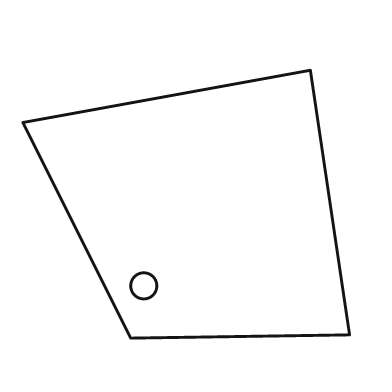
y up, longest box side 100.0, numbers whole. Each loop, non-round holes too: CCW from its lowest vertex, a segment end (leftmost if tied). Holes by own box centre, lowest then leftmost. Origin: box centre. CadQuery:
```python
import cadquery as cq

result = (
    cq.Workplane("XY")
    .moveTo(-17.0, -41.0)
    .lineTo(50.0, -40.0)
    .lineTo(38.0, 41.0)
    .lineTo(-50.0, 25.0)
    .close()
    .moveTo(-13.0, -25.0)
    .circle(4.0)
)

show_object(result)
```